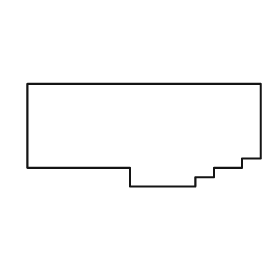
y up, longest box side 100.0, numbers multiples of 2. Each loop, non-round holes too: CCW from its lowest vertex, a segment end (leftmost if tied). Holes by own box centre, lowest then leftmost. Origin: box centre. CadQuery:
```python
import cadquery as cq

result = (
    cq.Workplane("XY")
    .moveTo(-6.0, -22.0)
    .lineTo(22.0, -22.0)
    .lineTo(22.0, -18.0)
    .lineTo(30.0, -18.0)
    .lineTo(30.0, -14.0)
    .lineTo(42.0, -14.0)
    .lineTo(42.0, -10.0)
    .lineTo(50.0, -10.0)
    .lineTo(50.0, 22.0)
    .lineTo(-50.0, 22.0)
    .lineTo(-50.0, -14.0)
    .lineTo(-6.0, -14.0)
    .close()
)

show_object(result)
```